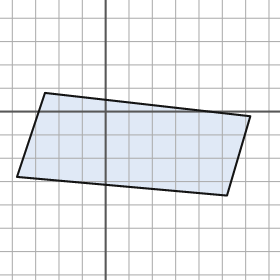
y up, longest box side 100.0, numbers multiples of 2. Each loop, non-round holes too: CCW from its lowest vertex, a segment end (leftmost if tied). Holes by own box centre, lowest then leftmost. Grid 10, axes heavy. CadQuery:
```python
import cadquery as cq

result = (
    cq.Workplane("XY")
    .moveTo(52.0, -36.0)
    .lineTo(62.0, -2.0)
    .lineTo(-26.0, 8.0)
    .lineTo(-38.0, -28.0)
    .close()
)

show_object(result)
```